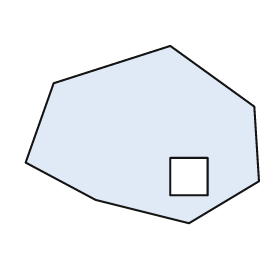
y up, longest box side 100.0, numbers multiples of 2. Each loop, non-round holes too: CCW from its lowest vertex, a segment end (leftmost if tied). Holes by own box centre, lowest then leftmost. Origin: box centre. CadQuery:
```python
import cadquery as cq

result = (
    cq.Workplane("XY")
    .moveTo(20.0, -38.0)
    .lineTo(50.0, -20.0)
    .lineTo(48.0, 12.0)
    .lineTo(12.0, 38.0)
    .lineTo(-38.0, 22.0)
    .lineTo(-50.0, -12.0)
    .lineTo(-20.0, -28.0)
    .close()
    .moveTo(12.0, -26.0)
    .lineTo(28.0, -26.0)
    .lineTo(28.0, -10.0)
    .lineTo(12.0, -10.0)
    .close()
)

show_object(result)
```